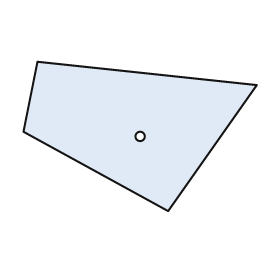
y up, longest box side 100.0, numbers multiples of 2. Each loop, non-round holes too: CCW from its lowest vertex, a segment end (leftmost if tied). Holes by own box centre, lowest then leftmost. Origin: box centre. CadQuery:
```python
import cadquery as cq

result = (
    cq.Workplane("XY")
    .moveTo(12.0, -32.0)
    .lineTo(50.0, 22.0)
    .lineTo(-44.0, 32.0)
    .lineTo(-50.0, 2.0)
    .close()
    .moveTo(0.0, 0.0)
    .circle(2.0)
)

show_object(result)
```